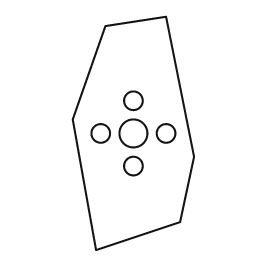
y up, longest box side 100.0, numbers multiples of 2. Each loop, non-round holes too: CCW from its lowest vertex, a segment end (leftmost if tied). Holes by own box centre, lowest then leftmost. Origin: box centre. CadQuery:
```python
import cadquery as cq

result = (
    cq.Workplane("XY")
    .moveTo(-16.0, -50.0)
    .lineTo(20.0, -38.0)
    .lineTo(26.0, -10.0)
    .lineTo(14.0, 50.0)
    .lineTo(-12.0, 46.0)
    .lineTo(-26.0, 6.0)
    .close()
    .moveTo(0.0, -14.0)
    .circle(4.0)
    .moveTo(-14.0, 0.0)
    .circle(4.0)
    .moveTo(0.0, 0.0)
    .circle(6.0)
    .moveTo(14.0, 0.0)
    .circle(4.0)
    .moveTo(0.0, 14.0)
    .circle(4.0)
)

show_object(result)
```